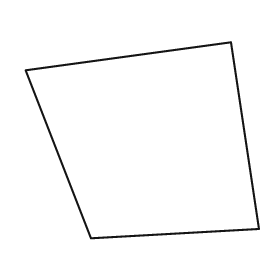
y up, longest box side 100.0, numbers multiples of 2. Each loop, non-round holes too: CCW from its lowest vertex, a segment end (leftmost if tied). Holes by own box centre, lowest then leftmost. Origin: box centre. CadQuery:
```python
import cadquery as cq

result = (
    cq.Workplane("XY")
    .moveTo(-22.0, -42.0)
    .lineTo(50.0, -38.0)
    .lineTo(38.0, 42.0)
    .lineTo(-50.0, 30.0)
    .close()
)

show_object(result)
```